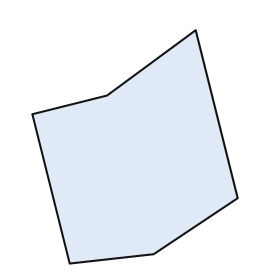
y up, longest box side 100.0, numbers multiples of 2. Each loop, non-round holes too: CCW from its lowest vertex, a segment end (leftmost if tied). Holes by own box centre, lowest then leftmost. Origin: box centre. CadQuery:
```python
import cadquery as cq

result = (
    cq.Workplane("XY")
    .moveTo(-28.0, -50.0)
    .lineTo(8.0, -46.0)
    .lineTo(44.0, -22.0)
    .lineTo(26.0, 50.0)
    .lineTo(-12.0, 22.0)
    .lineTo(-44.0, 14.0)
    .close()
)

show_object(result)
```